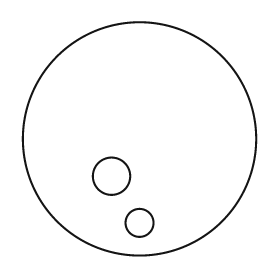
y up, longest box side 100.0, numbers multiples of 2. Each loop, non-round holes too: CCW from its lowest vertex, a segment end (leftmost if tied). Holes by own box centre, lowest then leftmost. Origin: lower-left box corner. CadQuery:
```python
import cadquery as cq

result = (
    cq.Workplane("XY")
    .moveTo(50.0, 50.0)
    .circle(50.0)
    .moveTo(50.0, 14.0)
    .circle(6.0)
    .moveTo(38.0, 34.0)
    .circle(8.0)
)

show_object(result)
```